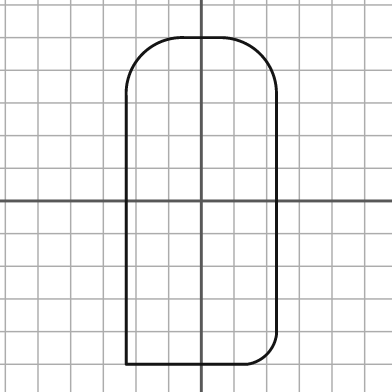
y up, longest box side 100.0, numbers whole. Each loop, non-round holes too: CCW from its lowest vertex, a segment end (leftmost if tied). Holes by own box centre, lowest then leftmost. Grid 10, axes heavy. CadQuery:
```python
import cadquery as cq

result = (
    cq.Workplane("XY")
    .moveTo(-23.0, -50.0)
    .lineTo(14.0, -50.0)
    .threePointArc((20.0, -47.0), (23.0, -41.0))
    .lineTo(23.0, 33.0)
    .threePointArc((18.0, 45.0), (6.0, 50.0))
    .lineTo(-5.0, 50.0)
    .threePointArc((-18.0, 45.0), (-23.0, 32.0))
    .close()
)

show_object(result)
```